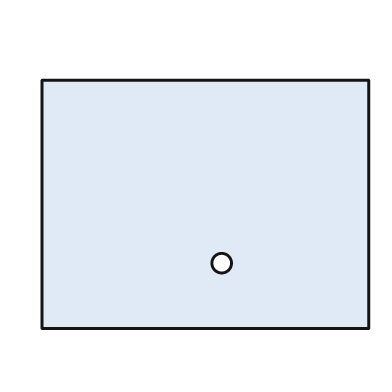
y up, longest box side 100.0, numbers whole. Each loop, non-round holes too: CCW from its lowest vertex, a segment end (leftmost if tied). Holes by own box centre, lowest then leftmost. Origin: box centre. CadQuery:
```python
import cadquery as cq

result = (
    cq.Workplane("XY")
    .moveTo(-50.0, -38.0)
    .lineTo(50.0, -38.0)
    .lineTo(50.0, 38.0)
    .lineTo(-50.0, 38.0)
    .close()
    .moveTo(5.0, -18.0)
    .circle(3.0)
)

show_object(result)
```